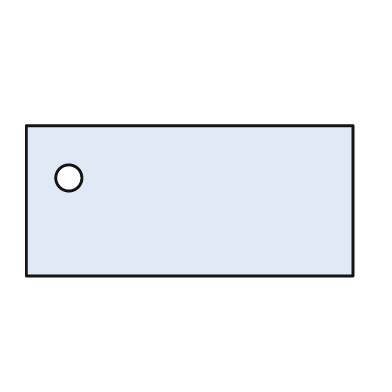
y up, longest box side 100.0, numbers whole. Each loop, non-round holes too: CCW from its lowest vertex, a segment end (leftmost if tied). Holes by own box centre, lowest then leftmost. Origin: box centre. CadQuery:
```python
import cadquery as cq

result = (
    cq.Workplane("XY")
    .moveTo(-50.0, -23.0)
    .lineTo(50.0, -23.0)
    .lineTo(50.0, 23.0)
    .lineTo(-50.0, 23.0)
    .close()
    .moveTo(-37.0, 7.0)
    .circle(4.0)
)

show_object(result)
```